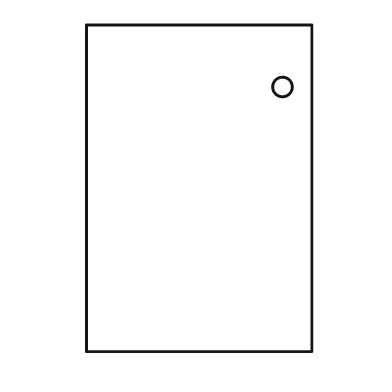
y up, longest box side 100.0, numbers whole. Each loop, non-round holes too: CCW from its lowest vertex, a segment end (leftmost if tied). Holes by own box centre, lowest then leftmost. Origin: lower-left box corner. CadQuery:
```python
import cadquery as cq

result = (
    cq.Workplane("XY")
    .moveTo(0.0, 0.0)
    .lineTo(69.0, 0.0)
    .lineTo(69.0, 100.0)
    .lineTo(0.0, 100.0)
    .close()
    .moveTo(60.0, 81.0)
    .circle(3.0)
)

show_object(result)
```